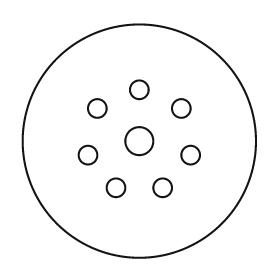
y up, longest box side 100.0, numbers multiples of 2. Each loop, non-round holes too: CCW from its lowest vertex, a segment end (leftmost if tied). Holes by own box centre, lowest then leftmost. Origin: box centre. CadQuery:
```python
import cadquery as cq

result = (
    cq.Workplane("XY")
    .moveTo(0.0, 0.0)
    .circle(50.0)
    .moveTo(-10.0, -20.0)
    .circle(4.0)
    .moveTo(10.0, -20.0)
    .circle(4.0)
    .moveTo(-22.0, -6.0)
    .circle(4.0)
    .moveTo(22.0, -6.0)
    .circle(4.0)
    .moveTo(0.0, 0.0)
    .circle(6.0)
    .moveTo(-18.0, 14.0)
    .circle(4.0)
    .moveTo(18.0, 14.0)
    .circle(4.0)
    .moveTo(0.0, 22.0)
    .circle(4.0)
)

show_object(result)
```